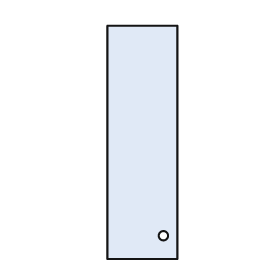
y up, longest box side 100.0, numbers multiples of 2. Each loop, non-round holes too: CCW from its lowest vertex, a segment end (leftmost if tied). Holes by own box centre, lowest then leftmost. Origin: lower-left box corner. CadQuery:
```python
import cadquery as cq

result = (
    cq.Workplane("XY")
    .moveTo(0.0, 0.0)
    .lineTo(30.0, 0.0)
    .lineTo(30.0, 100.0)
    .lineTo(0.0, 100.0)
    .close()
    .moveTo(24.0, 10.0)
    .circle(2.0)
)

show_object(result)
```